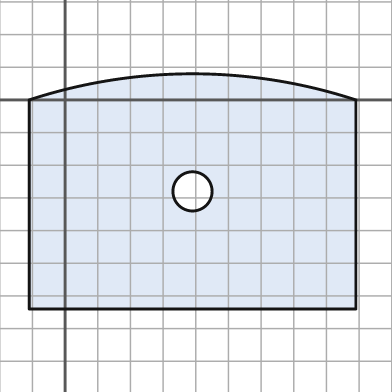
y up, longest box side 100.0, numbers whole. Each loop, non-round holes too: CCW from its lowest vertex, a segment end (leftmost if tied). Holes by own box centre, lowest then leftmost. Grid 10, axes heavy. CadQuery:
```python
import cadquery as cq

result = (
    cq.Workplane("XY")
    .moveTo(-11.0, -64.0)
    .lineTo(89.0, -64.0)
    .lineTo(89.0, 0.0)
    .threePointArc((39.0, 8.0), (-11.0, 0.0))
    .close()
    .moveTo(39.0, -28.0)
    .circle(6.0)
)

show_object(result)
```